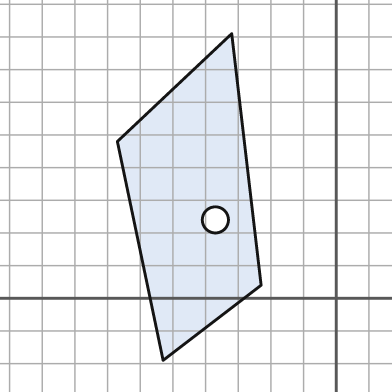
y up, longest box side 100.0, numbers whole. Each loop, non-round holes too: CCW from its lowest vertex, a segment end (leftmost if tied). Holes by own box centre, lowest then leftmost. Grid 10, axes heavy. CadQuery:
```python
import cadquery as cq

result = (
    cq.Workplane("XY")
    .moveTo(-53.0, -19.0)
    .lineTo(-23.0, 4.0)
    .lineTo(-32.0, 81.0)
    .lineTo(-67.0, 48.0)
    .close()
    .moveTo(-37.0, 24.0)
    .circle(4.0)
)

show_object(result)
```